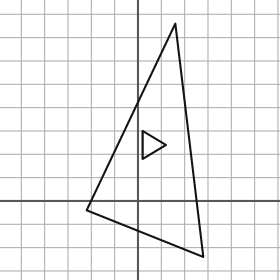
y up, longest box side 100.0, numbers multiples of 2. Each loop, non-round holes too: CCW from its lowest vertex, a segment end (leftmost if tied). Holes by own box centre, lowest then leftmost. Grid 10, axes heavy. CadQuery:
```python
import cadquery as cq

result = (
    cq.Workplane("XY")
    .moveTo(28.0, -24.0)
    .lineTo(16.0, 76.0)
    .lineTo(-22.0, -4.0)
    .close()
    .moveTo(2.0, 18.0)
    .lineTo(12.0, 24.0)
    .lineTo(2.0, 30.0)
    .close()
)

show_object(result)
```